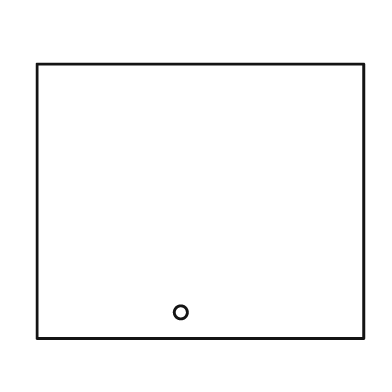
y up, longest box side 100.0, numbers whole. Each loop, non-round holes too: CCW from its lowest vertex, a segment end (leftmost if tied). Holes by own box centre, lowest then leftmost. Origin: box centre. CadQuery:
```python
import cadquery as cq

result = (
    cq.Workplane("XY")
    .moveTo(-50.0, -42.0)
    .lineTo(50.0, -42.0)
    .lineTo(50.0, 42.0)
    .lineTo(-50.0, 42.0)
    .close()
    .moveTo(-6.0, -34.0)
    .circle(2.0)
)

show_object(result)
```